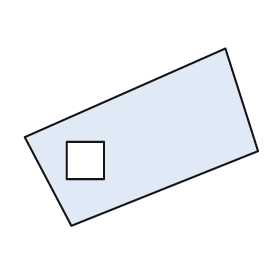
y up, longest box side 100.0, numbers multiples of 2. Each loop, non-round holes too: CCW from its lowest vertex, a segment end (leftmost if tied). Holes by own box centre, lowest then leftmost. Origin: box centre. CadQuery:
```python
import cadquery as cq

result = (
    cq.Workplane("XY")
    .moveTo(-30.0, -38.0)
    .lineTo(50.0, -6.0)
    .lineTo(36.0, 38.0)
    .lineTo(-50.0, 0.0)
    .close()
    .moveTo(-32.0, -18.0)
    .lineTo(-16.0, -18.0)
    .lineTo(-16.0, -2.0)
    .lineTo(-32.0, -2.0)
    .close()
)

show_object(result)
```